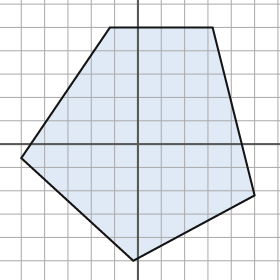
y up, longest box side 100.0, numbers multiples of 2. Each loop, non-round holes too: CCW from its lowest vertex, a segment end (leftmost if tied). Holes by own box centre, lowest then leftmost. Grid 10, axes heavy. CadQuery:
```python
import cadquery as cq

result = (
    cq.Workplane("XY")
    .moveTo(-2.0, -50.0)
    .lineTo(50.0, -22.0)
    .lineTo(32.0, 50.0)
    .lineTo(-12.0, 50.0)
    .lineTo(-50.0, -6.0)
    .close()
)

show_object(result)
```